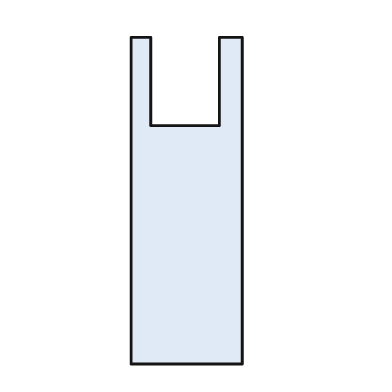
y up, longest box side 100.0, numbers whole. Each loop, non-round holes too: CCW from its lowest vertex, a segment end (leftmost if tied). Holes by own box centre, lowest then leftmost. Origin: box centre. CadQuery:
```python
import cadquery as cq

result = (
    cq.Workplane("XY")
    .moveTo(-17.0, -50.0)
    .lineTo(17.0, -50.0)
    .lineTo(17.0, 50.0)
    .lineTo(10.0, 50.0)
    .lineTo(10.0, 23.0)
    .lineTo(-11.0, 23.0)
    .lineTo(-11.0, 50.0)
    .lineTo(-17.0, 50.0)
    .close()
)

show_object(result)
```